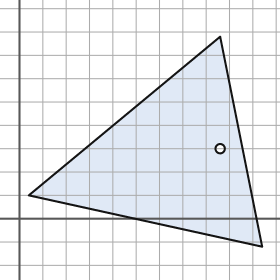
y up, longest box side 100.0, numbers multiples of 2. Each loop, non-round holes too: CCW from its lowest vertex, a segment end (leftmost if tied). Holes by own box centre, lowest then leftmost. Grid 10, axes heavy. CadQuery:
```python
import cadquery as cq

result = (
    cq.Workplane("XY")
    .moveTo(104.0, -12.0)
    .lineTo(86.0, 78.0)
    .lineTo(4.0, 10.0)
    .close()
    .moveTo(86.0, 30.0)
    .circle(2.0)
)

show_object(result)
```